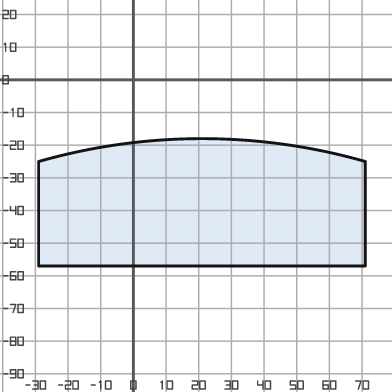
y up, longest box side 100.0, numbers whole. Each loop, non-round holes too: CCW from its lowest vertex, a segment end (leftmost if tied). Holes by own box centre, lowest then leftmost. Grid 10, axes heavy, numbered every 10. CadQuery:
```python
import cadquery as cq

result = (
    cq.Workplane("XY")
    .moveTo(-29.0, -57.0)
    .lineTo(71.0, -57.0)
    .lineTo(71.0, -25.0)
    .threePointArc((21.0, -18.0), (-29.0, -25.0))
    .close()
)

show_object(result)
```